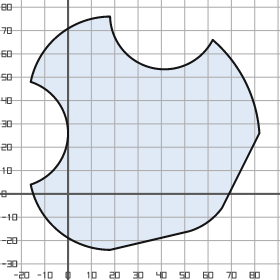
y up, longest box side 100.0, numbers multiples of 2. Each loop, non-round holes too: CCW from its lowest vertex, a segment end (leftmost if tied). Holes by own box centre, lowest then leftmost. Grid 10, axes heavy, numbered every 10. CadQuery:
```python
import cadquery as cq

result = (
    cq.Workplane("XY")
    .moveTo(18.0, -24.0)
    .lineTo(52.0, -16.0)
    .threePointArc((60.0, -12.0), (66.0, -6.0))
    .lineTo(82.0, 26.0)
    .threePointArc((76.0, 48.0), (62.0, 66.0))
    .threePointArc((36.0, 54.0), (18.0, 76.0))
    .threePointArc((-4.0, 68.0), (-16.0, 48.0))
    .threePointArc((0.0, 26.0), (-16.0, 4.0))
    .threePointArc((-4.0, -16.0), (18.0, -24.0))
    .close()
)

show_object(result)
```